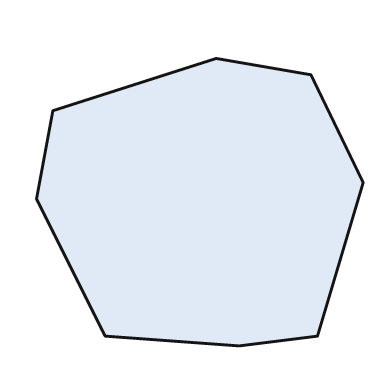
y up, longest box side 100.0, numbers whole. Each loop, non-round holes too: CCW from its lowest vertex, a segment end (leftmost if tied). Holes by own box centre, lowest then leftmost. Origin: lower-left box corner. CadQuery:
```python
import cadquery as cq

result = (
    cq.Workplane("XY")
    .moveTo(62.0, 0.0)
    .lineTo(86.0, 3.0)
    .lineTo(100.0, 50.0)
    .lineTo(84.0, 83.0)
    .lineTo(55.0, 88.0)
    .lineTo(5.0, 72.0)
    .lineTo(0.0, 45.0)
    .lineTo(21.0, 3.0)
    .close()
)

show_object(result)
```